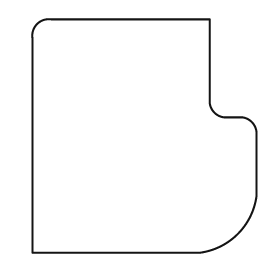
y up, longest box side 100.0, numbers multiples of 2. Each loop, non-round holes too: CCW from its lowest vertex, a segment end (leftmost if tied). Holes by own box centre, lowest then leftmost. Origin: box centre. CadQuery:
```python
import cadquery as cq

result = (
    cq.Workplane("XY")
    .moveTo(-48.0, -50.0)
    .lineTo(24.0, -50.0)
    .threePointArc((40.0, -42.0), (48.0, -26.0))
    .lineTo(48.0, 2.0)
    .threePointArc((46.0, 6.0), (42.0, 8.0))
    .lineTo(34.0, 8.0)
    .threePointArc((30.0, 10.0), (28.0, 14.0))
    .lineTo(28.0, 50.0)
    .lineTo(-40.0, 50.0)
    .threePointArc((-46.0, 48.0), (-48.0, 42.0))
    .close()
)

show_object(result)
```